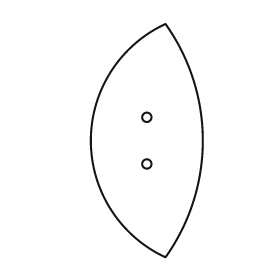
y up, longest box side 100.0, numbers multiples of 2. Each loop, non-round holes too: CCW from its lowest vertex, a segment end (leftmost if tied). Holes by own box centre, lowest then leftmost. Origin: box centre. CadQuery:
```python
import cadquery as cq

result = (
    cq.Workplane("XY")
    .moveTo(8.0, -50.0)
    .threePointArc((24.0, 0.0), (8.0, 50.0))
    .threePointArc((-24.0, 0.0), (8.0, -50.0))
    .close()
    .moveTo(0.0, -10.0)
    .circle(2.0)
    .moveTo(0.0, 10.0)
    .circle(2.0)
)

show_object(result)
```